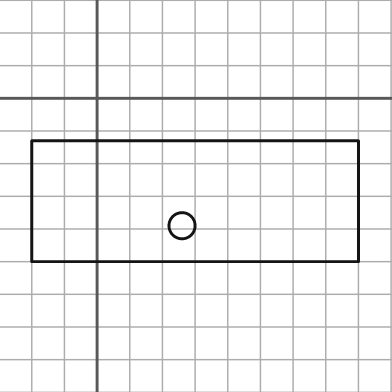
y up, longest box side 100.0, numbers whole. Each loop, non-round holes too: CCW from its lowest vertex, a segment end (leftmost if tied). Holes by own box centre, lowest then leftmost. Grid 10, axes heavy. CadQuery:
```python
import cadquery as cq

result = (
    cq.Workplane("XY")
    .moveTo(-20.0, -50.0)
    .lineTo(80.0, -50.0)
    .lineTo(80.0, -13.0)
    .lineTo(-20.0, -13.0)
    .close()
    .moveTo(26.0, -39.0)
    .circle(4.0)
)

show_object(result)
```